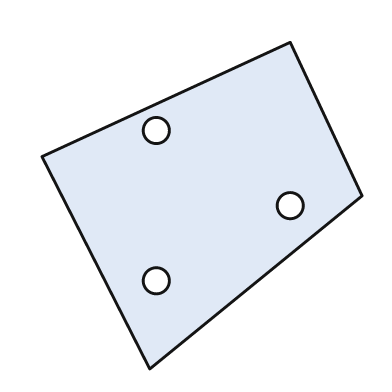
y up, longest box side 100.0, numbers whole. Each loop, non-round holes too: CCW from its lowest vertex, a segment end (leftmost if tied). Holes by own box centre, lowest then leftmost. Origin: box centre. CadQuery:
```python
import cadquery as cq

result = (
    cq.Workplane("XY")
    .moveTo(-16.0, -50.0)
    .lineTo(49.0, 3.0)
    .lineTo(27.0, 50.0)
    .lineTo(-49.0, 15.0)
    .close()
    .moveTo(-14.0, -23.0)
    .circle(4.0)
    .moveTo(27.0, 0.0)
    .circle(4.0)
    .moveTo(-14.0, 23.0)
    .circle(4.0)
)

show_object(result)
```